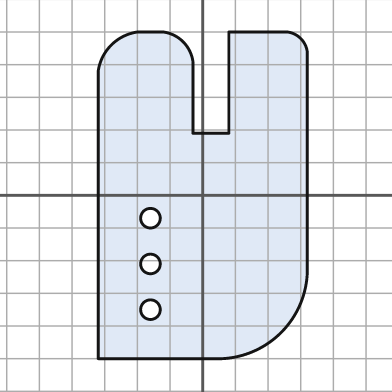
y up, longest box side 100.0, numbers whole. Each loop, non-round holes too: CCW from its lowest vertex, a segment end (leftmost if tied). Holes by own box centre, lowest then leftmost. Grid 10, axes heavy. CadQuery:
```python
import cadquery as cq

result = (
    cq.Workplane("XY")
    .moveTo(-32.0, -50.0)
    .lineTo(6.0, -50.0)
    .threePointArc((24.0, -42.0), (32.0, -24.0))
    .lineTo(32.0, 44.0)
    .threePointArc((30.0, 48.0), (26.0, 50.0))
    .lineTo(8.0, 50.0)
    .lineTo(8.0, 19.0)
    .lineTo(-3.0, 19.0)
    .lineTo(-3.0, 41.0)
    .threePointArc((-6.0, 47.0), (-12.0, 50.0))
    .lineTo(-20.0, 50.0)
    .threePointArc((-28.0, 46.0), (-32.0, 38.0))
    .close()
    .moveTo(-16.0, -35.0)
    .circle(3.0)
    .moveTo(-16.0, -21.0)
    .circle(3.0)
    .moveTo(-16.0, -7.0)
    .circle(3.0)
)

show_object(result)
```